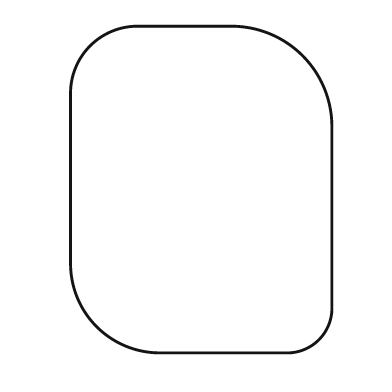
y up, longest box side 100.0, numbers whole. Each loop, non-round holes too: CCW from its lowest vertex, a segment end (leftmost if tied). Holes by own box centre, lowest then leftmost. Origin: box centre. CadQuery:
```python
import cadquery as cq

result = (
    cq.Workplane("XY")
    .moveTo(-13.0, -50.0)
    .lineTo(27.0, -50.0)
    .threePointArc((36.0, -46.0), (40.0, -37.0))
    .lineTo(40.0, 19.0)
    .threePointArc((31.0, 41.0), (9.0, 50.0))
    .lineTo(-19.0, 50.0)
    .threePointArc((-34.0, 44.0), (-40.0, 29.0))
    .lineTo(-40.0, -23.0)
    .threePointArc((-32.0, -42.0), (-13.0, -50.0))
    .close()
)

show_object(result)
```